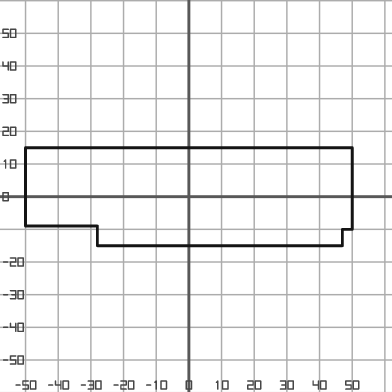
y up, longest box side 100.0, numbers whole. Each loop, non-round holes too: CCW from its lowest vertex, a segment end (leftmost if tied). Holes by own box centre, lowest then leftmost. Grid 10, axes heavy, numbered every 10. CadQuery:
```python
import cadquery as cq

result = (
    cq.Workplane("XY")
    .moveTo(-28.0, -15.0)
    .lineTo(47.0, -15.0)
    .lineTo(47.0, -10.0)
    .lineTo(50.0, -10.0)
    .lineTo(50.0, 15.0)
    .lineTo(-50.0, 15.0)
    .lineTo(-50.0, -9.0)
    .lineTo(-28.0, -9.0)
    .close()
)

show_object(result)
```